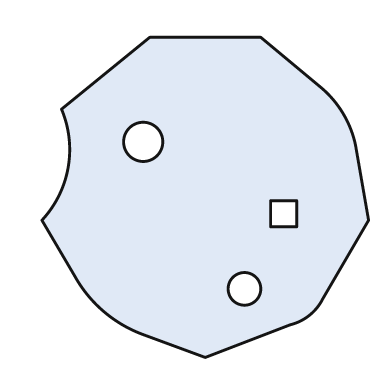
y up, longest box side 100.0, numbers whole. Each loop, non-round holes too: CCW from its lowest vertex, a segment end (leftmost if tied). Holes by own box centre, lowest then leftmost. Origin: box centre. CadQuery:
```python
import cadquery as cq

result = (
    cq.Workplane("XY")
    .moveTo(0.0, -49.0)
    .lineTo(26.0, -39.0)
    .threePointArc((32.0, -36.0), (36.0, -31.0))
    .lineTo(50.0, -7.0)
    .lineTo(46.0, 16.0)
    .threePointArc((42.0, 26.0), (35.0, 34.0))
    .lineTo(17.0, 49.0)
    .lineTo(-17.0, 49.0)
    .lineTo(-44.0, 27.0)
    .threePointArc((-42.0, 9.0), (-50.0, -7.0))
    .lineTo(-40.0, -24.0)
    .threePointArc((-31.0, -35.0), (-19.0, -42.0))
    .close()
    .moveTo(12.0, -28.0)
    .circle(5.0)
    .moveTo(20.0, -9.0)
    .lineTo(28.0, -9.0)
    .lineTo(28.0, -1.0)
    .lineTo(20.0, -1.0)
    .close()
    .moveTo(-19.0, 17.0)
    .circle(6.0)
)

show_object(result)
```